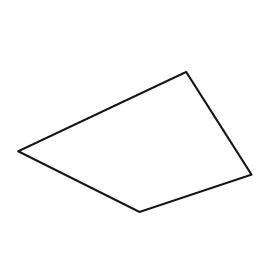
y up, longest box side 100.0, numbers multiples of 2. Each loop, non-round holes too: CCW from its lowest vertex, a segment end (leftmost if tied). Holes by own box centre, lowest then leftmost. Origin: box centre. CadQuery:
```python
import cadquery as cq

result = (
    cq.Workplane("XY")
    .moveTo(2.0, -30.0)
    .lineTo(50.0, -14.0)
    .lineTo(22.0, 30.0)
    .lineTo(-50.0, -4.0)
    .close()
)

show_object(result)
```